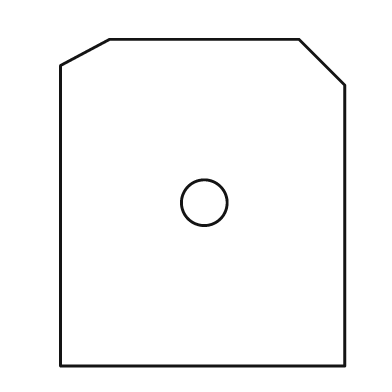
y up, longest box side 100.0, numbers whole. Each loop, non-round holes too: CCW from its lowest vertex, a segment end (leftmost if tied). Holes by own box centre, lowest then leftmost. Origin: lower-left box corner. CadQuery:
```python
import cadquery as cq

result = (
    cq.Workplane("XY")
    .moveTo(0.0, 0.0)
    .lineTo(87.0, 0.0)
    .lineTo(87.0, 86.0)
    .lineTo(73.0, 100.0)
    .lineTo(15.0, 100.0)
    .lineTo(0.0, 92.0)
    .close()
    .moveTo(44.0, 50.0)
    .circle(7.0)
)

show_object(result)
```